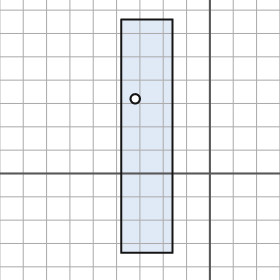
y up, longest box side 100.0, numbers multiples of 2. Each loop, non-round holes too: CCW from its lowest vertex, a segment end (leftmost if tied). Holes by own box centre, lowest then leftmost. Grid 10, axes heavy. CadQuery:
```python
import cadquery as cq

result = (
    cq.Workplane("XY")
    .moveTo(-38.0, -34.0)
    .lineTo(-16.0, -34.0)
    .lineTo(-16.0, 66.0)
    .lineTo(-38.0, 66.0)
    .close()
    .moveTo(-32.0, 32.0)
    .circle(2.0)
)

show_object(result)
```